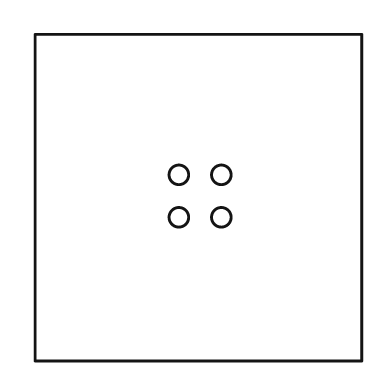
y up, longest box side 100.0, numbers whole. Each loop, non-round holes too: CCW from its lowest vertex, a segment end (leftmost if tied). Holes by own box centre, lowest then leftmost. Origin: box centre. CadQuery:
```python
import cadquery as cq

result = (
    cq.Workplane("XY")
    .moveTo(-50.0, -50.0)
    .lineTo(50.0, -50.0)
    .lineTo(50.0, 50.0)
    .lineTo(-50.0, 50.0)
    .close()
    .moveTo(-6.0, -6.0)
    .circle(3.0)
    .moveTo(7.0, -6.0)
    .circle(3.0)
    .moveTo(-6.0, 7.0)
    .circle(3.0)
    .moveTo(7.0, 7.0)
    .circle(3.0)
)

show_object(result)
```